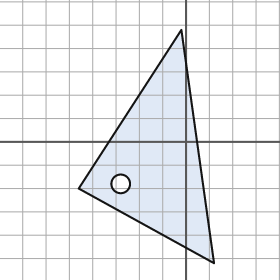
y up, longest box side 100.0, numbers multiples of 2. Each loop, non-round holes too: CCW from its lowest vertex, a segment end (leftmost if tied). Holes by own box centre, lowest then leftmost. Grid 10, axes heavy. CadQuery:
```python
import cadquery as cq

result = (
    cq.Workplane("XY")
    .moveTo(12.0, -52.0)
    .lineTo(-2.0, 48.0)
    .lineTo(-46.0, -20.0)
    .close()
    .moveTo(-28.0, -18.0)
    .circle(4.0)
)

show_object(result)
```